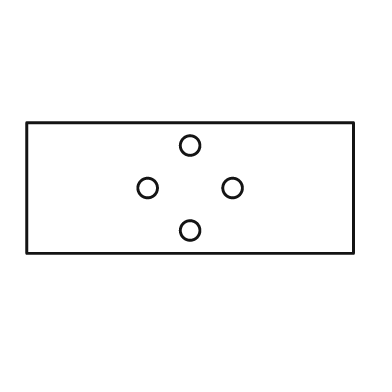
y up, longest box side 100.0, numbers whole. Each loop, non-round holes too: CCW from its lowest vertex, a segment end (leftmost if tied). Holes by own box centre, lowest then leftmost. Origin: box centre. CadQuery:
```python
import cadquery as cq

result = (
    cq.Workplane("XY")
    .moveTo(-50.0, -20.0)
    .lineTo(50.0, -20.0)
    .lineTo(50.0, 20.0)
    .lineTo(-50.0, 20.0)
    .close()
    .moveTo(0.0, -13.0)
    .circle(3.0)
    .moveTo(-13.0, 0.0)
    .circle(3.0)
    .moveTo(13.0, 0.0)
    .circle(3.0)
    .moveTo(0.0, 13.0)
    .circle(3.0)
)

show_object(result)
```